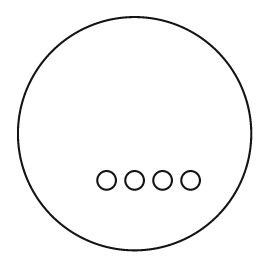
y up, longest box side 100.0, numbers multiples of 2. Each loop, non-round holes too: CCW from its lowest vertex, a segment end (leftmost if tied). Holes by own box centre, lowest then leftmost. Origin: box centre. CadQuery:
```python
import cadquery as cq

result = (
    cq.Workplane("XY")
    .moveTo(0.0, 0.0)
    .circle(50.0)
    .moveTo(-12.0, -20.0)
    .circle(4.0)
    .moveTo(0.0, -20.0)
    .circle(4.0)
    .moveTo(12.0, -20.0)
    .circle(4.0)
    .moveTo(24.0, -20.0)
    .circle(4.0)
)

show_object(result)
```